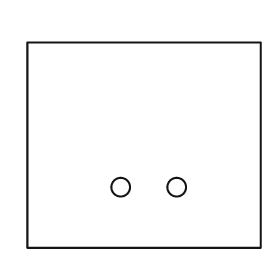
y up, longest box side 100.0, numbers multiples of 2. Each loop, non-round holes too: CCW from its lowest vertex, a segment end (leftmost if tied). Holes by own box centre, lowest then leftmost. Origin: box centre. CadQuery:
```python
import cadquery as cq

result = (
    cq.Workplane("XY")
    .moveTo(-50.0, -44.0)
    .lineTo(50.0, -44.0)
    .lineTo(50.0, 44.0)
    .lineTo(-50.0, 44.0)
    .close()
    .moveTo(-10.0, -18.0)
    .circle(4.0)
    .moveTo(14.0, -18.0)
    .circle(4.0)
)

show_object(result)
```